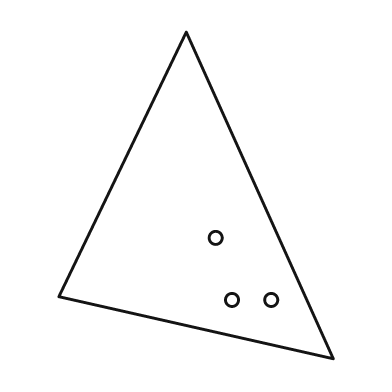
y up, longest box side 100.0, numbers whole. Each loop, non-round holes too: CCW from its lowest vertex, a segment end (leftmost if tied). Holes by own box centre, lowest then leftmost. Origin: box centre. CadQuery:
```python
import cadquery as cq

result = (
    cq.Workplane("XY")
    .moveTo(42.0, -50.0)
    .lineTo(-3.0, 50.0)
    .lineTo(-42.0, -31.0)
    .close()
    .moveTo(11.0, -32.0)
    .circle(2.0)
    .moveTo(23.0, -32.0)
    .circle(2.0)
    .moveTo(6.0, -13.0)
    .circle(2.0)
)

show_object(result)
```